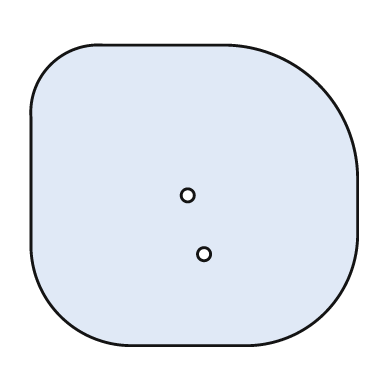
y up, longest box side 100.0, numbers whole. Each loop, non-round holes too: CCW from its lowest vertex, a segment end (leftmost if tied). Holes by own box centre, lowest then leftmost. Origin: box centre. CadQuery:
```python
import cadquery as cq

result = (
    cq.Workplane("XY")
    .moveTo(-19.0, -46.0)
    .lineTo(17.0, -46.0)
    .threePointArc((40.0, -36.0), (50.0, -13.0))
    .lineTo(50.0, 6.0)
    .threePointArc((38.0, 34.0), (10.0, 46.0))
    .lineTo(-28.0, 46.0)
    .threePointArc((-44.0, 40.0), (-50.0, 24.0))
    .lineTo(-50.0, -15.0)
    .threePointArc((-41.0, -37.0), (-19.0, -46.0))
    .close()
    .moveTo(3.0, -18.0)
    .circle(2.0)
    .moveTo(-2.0, 0.0)
    .circle(2.0)
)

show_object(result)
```